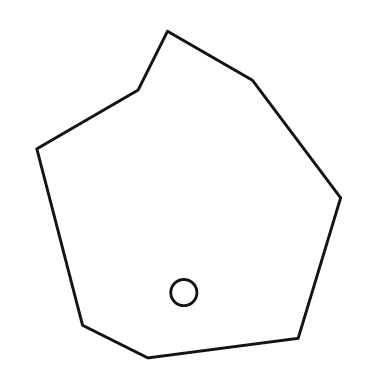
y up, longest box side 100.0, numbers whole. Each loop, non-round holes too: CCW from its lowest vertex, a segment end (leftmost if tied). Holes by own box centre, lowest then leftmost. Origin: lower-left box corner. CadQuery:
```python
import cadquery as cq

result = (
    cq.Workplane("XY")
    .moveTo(34.0, 0.0)
    .lineTo(80.0, 6.0)
    .lineTo(93.0, 49.0)
    .lineTo(66.0, 85.0)
    .lineTo(40.0, 100.0)
    .lineTo(31.0, 82.0)
    .lineTo(0.0, 64.0)
    .lineTo(14.0, 10.0)
    .close()
    .moveTo(45.0, 20.0)
    .circle(4.0)
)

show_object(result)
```